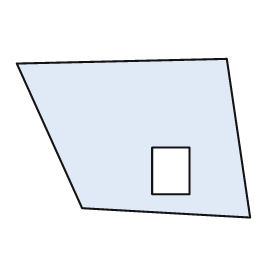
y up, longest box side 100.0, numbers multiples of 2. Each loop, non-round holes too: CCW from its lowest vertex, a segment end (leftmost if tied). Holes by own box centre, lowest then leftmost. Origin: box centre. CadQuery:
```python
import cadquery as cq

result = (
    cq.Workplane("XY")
    .moveTo(50.0, -34.0)
    .lineTo(40.0, 34.0)
    .lineTo(-50.0, 32.0)
    .lineTo(-22.0, -30.0)
    .close()
    .moveTo(8.0, -24.0)
    .lineTo(24.0, -24.0)
    .lineTo(24.0, -4.0)
    .lineTo(8.0, -4.0)
    .close()
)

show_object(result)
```